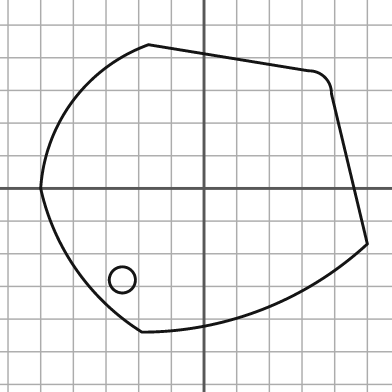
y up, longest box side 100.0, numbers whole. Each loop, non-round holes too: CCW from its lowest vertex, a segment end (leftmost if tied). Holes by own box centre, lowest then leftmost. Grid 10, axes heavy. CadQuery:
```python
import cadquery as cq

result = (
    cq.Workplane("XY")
    .moveTo(-19.0, -44.0)
    .threePointArc((18.0, -37.0), (50.0, -17.0))
    .lineTo(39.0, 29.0)
    .threePointArc((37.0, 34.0), (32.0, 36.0))
    .lineTo(-17.0, 44.0)
    .threePointArc((-40.0, 27.0), (-50.0, 0.0))
    .threePointArc((-39.0, -25.0), (-19.0, -44.0))
    .close()
    .moveTo(-25.0, -28.0)
    .circle(4.0)
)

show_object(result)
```